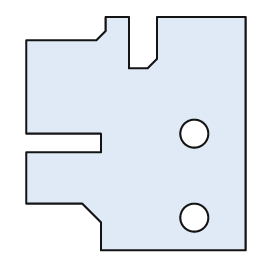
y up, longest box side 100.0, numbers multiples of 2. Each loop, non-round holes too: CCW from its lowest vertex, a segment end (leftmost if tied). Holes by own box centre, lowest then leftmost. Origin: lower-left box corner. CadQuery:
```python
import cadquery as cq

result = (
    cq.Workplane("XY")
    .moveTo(32.0, 0.0)
    .lineTo(94.0, 0.0)
    .lineTo(94.0, 100.0)
    .lineTo(56.0, 100.0)
    .lineTo(56.0, 82.0)
    .lineTo(52.0, 78.0)
    .lineTo(44.0, 78.0)
    .lineTo(44.0, 100.0)
    .lineTo(34.0, 100.0)
    .lineTo(34.0, 94.0)
    .lineTo(30.0, 90.0)
    .lineTo(0.0, 90.0)
    .lineTo(0.0, 50.0)
    .lineTo(32.0, 50.0)
    .lineTo(32.0, 42.0)
    .lineTo(0.0, 42.0)
    .lineTo(0.0, 20.0)
    .lineTo(24.0, 20.0)
    .lineTo(32.0, 12.0)
    .close()
    .moveTo(72.0, 14.0)
    .circle(6.0)
    .moveTo(72.0, 50.0)
    .circle(6.0)
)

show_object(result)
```